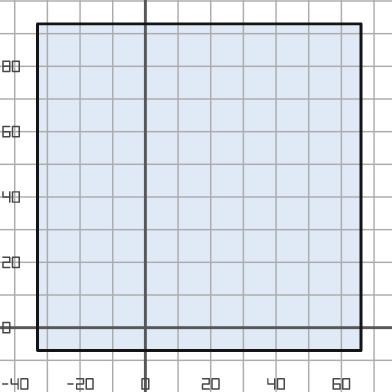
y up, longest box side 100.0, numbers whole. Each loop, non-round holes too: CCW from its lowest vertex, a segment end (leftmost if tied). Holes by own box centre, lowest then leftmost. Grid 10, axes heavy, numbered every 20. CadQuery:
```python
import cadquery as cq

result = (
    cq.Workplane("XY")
    .moveTo(-33.0, -7.0)
    .lineTo(66.0, -7.0)
    .lineTo(66.0, 93.0)
    .lineTo(-33.0, 93.0)
    .close()
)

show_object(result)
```